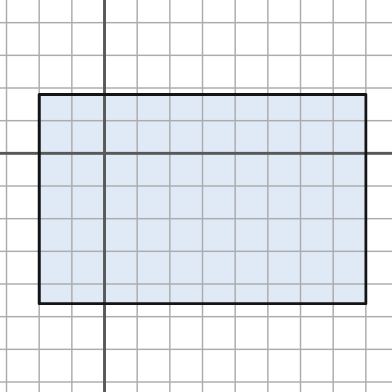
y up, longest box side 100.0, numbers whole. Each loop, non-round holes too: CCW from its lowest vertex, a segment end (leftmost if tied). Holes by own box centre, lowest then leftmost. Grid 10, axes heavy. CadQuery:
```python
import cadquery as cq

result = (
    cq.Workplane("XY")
    .moveTo(-20.0, -46.0)
    .lineTo(80.0, -46.0)
    .lineTo(80.0, 18.0)
    .lineTo(-20.0, 18.0)
    .close()
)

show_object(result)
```